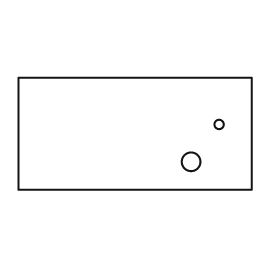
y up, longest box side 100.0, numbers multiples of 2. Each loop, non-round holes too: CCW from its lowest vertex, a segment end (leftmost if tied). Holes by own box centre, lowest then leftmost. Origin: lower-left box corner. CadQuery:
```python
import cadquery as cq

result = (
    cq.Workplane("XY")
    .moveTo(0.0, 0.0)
    .lineTo(100.0, 0.0)
    .lineTo(100.0, 48.0)
    .lineTo(0.0, 48.0)
    .close()
    .moveTo(74.0, 12.0)
    .circle(4.0)
    .moveTo(86.0, 28.0)
    .circle(2.0)
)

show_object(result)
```